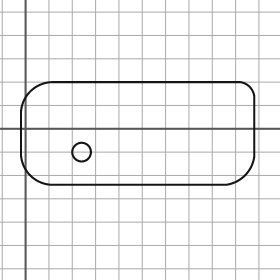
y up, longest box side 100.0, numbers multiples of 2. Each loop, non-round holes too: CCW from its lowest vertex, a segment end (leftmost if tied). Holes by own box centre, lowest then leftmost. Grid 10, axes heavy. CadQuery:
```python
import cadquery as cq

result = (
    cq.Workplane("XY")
    .moveTo(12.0, -24.0)
    .lineTo(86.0, -24.0)
    .threePointArc((94.0, -20.0), (98.0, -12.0))
    .lineTo(98.0, 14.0)
    .threePointArc((96.0, 18.0), (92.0, 20.0))
    .lineTo(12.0, 20.0)
    .threePointArc((2.0, 16.0), (-2.0, 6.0))
    .lineTo(-2.0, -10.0)
    .threePointArc((2.0, -20.0), (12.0, -24.0))
    .close()
    .moveTo(24.0, -10.0)
    .circle(4.0)
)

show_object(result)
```